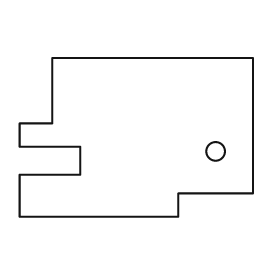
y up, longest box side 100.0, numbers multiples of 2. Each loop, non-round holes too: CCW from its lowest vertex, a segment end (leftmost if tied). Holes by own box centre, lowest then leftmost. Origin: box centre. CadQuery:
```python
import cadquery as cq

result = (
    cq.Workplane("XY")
    .moveTo(-50.0, -34.0)
    .lineTo(18.0, -34.0)
    .lineTo(18.0, -24.0)
    .lineTo(50.0, -24.0)
    .lineTo(50.0, 34.0)
    .lineTo(-36.0, 34.0)
    .lineTo(-36.0, 6.0)
    .lineTo(-50.0, 6.0)
    .lineTo(-50.0, -4.0)
    .lineTo(-24.0, -4.0)
    .lineTo(-24.0, -16.0)
    .lineTo(-50.0, -16.0)
    .close()
    .moveTo(34.0, -6.0)
    .circle(4.0)
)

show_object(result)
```